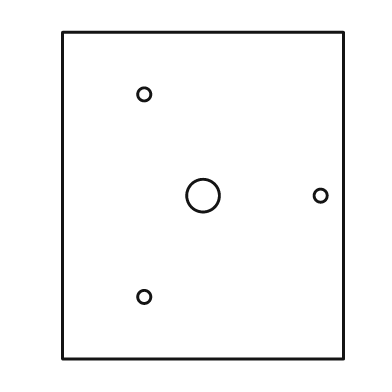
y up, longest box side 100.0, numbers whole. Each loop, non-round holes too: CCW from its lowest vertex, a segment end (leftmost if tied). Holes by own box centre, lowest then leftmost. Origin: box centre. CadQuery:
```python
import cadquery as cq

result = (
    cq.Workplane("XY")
    .moveTo(-43.0, -50.0)
    .lineTo(43.0, -50.0)
    .lineTo(43.0, 50.0)
    .lineTo(-43.0, 50.0)
    .close()
    .moveTo(-18.0, -31.0)
    .circle(2.0)
    .moveTo(0.0, 0.0)
    .circle(5.0)
    .moveTo(36.0, 0.0)
    .circle(2.0)
    .moveTo(-18.0, 31.0)
    .circle(2.0)
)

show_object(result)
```